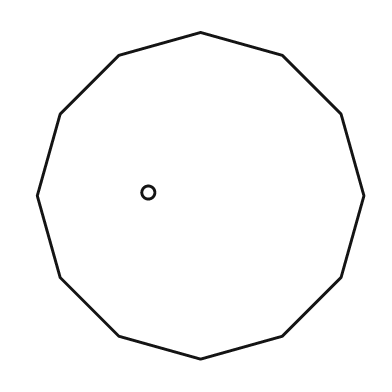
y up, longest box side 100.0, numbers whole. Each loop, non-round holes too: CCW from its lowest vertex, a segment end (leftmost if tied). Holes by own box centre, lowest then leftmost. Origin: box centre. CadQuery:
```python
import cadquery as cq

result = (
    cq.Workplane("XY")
    .moveTo(0.0, -50.0)
    .lineTo(25.0, -43.0)
    .lineTo(43.0, -25.0)
    .lineTo(50.0, 0.0)
    .lineTo(43.0, 25.0)
    .lineTo(25.0, 43.0)
    .lineTo(0.0, 50.0)
    .lineTo(-25.0, 43.0)
    .lineTo(-43.0, 25.0)
    .lineTo(-50.0, 0.0)
    .lineTo(-43.0, -25.0)
    .lineTo(-25.0, -43.0)
    .close()
    .moveTo(-16.0, 1.0)
    .circle(2.0)
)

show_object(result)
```